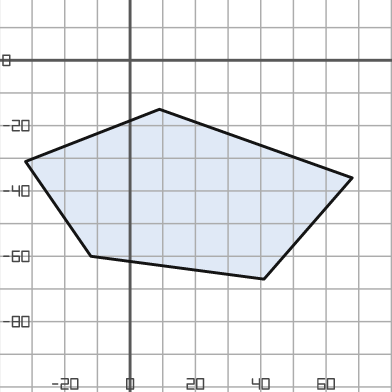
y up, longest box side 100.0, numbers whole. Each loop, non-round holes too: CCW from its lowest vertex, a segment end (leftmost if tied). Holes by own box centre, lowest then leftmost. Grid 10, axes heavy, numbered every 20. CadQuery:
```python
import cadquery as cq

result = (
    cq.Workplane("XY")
    .moveTo(41.0, -67.0)
    .lineTo(68.0, -36.0)
    .lineTo(9.0, -15.0)
    .lineTo(-32.0, -31.0)
    .lineTo(-12.0, -60.0)
    .close()
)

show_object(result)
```